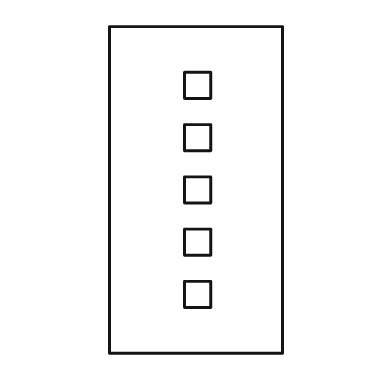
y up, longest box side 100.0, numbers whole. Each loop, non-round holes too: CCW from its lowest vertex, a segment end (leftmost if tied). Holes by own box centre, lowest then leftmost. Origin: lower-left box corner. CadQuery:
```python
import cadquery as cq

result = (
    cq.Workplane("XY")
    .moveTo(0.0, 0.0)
    .lineTo(53.0, 0.0)
    .lineTo(53.0, 100.0)
    .lineTo(0.0, 100.0)
    .close()
    .moveTo(23.0, 14.0)
    .lineTo(31.0, 14.0)
    .lineTo(31.0, 22.0)
    .lineTo(23.0, 22.0)
    .close()
    .moveTo(23.0, 30.0)
    .lineTo(31.0, 30.0)
    .lineTo(31.0, 38.0)
    .lineTo(23.0, 38.0)
    .close()
    .moveTo(23.0, 46.0)
    .lineTo(31.0, 46.0)
    .lineTo(31.0, 54.0)
    .lineTo(23.0, 54.0)
    .close()
    .moveTo(23.0, 62.0)
    .lineTo(31.0, 62.0)
    .lineTo(31.0, 70.0)
    .lineTo(23.0, 70.0)
    .close()
    .moveTo(23.0, 78.0)
    .lineTo(31.0, 78.0)
    .lineTo(31.0, 86.0)
    .lineTo(23.0, 86.0)
    .close()
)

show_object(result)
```